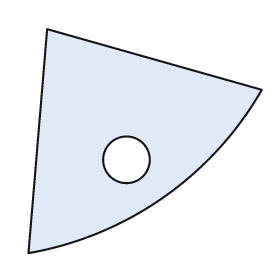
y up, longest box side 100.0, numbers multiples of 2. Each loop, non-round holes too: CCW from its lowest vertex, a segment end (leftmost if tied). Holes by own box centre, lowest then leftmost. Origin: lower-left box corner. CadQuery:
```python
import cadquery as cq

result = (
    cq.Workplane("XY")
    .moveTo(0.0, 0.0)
    .threePointArc((58.0, 24.0), (100.0, 70.0))
    .lineTo(8.0, 96.0)
    .close()
    .moveTo(42.0, 40.0)
    .circle(10.0)
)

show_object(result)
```